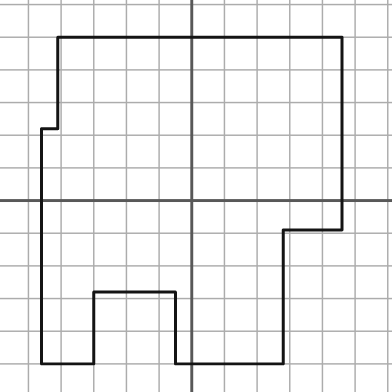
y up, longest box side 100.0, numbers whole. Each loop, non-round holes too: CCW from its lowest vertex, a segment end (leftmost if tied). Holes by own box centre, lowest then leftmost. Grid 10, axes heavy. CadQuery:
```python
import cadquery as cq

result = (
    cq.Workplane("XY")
    .moveTo(-46.0, -50.0)
    .lineTo(-30.0, -50.0)
    .lineTo(-30.0, -28.0)
    .lineTo(-5.0, -28.0)
    .lineTo(-5.0, -50.0)
    .lineTo(28.0, -50.0)
    .lineTo(28.0, -9.0)
    .lineTo(46.0, -9.0)
    .lineTo(46.0, 50.0)
    .lineTo(-41.0, 50.0)
    .lineTo(-41.0, 22.0)
    .lineTo(-46.0, 22.0)
    .close()
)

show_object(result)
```